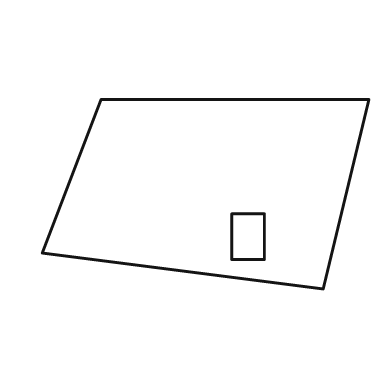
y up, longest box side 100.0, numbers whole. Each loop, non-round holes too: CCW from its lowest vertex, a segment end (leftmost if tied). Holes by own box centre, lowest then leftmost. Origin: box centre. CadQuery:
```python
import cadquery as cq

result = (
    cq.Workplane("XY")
    .moveTo(36.0, -29.0)
    .lineTo(50.0, 29.0)
    .lineTo(-32.0, 29.0)
    .lineTo(-50.0, -18.0)
    .close()
    .moveTo(8.0, -20.0)
    .lineTo(18.0, -20.0)
    .lineTo(18.0, -6.0)
    .lineTo(8.0, -6.0)
    .close()
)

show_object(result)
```